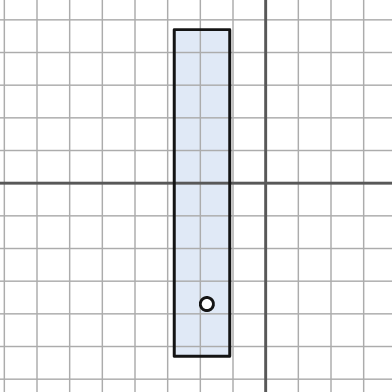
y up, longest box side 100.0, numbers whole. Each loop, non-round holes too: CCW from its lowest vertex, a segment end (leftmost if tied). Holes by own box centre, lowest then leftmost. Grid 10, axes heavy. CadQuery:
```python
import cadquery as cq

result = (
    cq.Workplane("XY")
    .moveTo(-28.0, -53.0)
    .lineTo(-11.0, -53.0)
    .lineTo(-11.0, 47.0)
    .lineTo(-28.0, 47.0)
    .close()
    .moveTo(-18.0, -37.0)
    .circle(2.0)
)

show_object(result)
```